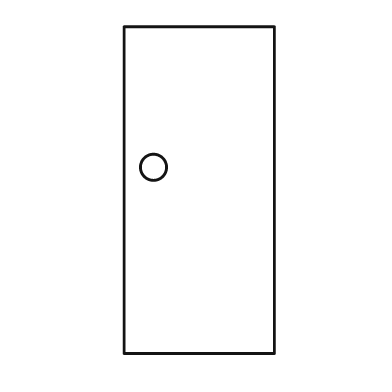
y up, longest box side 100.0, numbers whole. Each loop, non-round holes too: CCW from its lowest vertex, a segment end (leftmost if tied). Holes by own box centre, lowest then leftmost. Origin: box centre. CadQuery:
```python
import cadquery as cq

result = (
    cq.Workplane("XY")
    .moveTo(-23.0, -50.0)
    .lineTo(23.0, -50.0)
    .lineTo(23.0, 50.0)
    .lineTo(-23.0, 50.0)
    .close()
    .moveTo(-14.0, 7.0)
    .circle(4.0)
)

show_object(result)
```